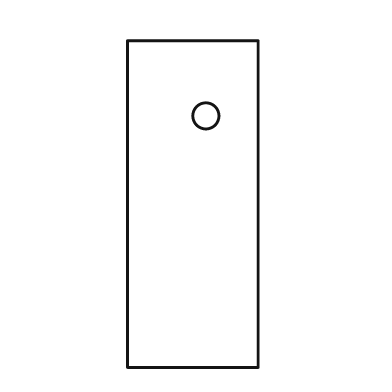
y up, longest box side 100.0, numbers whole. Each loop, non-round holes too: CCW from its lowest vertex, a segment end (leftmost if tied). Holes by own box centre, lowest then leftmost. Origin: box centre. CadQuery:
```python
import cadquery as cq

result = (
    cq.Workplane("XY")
    .moveTo(-20.0, -50.0)
    .lineTo(20.0, -50.0)
    .lineTo(20.0, 50.0)
    .lineTo(-20.0, 50.0)
    .close()
    .moveTo(4.0, 27.0)
    .circle(4.0)
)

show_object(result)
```